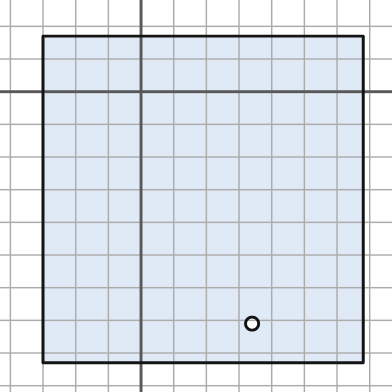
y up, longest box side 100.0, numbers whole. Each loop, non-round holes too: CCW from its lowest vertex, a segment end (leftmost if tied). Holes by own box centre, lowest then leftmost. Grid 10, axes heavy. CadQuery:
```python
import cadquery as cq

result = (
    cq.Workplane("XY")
    .moveTo(-30.0, -83.0)
    .lineTo(68.0, -83.0)
    .lineTo(68.0, 17.0)
    .lineTo(-30.0, 17.0)
    .close()
    .moveTo(34.0, -71.0)
    .circle(2.0)
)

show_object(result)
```